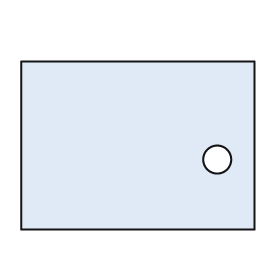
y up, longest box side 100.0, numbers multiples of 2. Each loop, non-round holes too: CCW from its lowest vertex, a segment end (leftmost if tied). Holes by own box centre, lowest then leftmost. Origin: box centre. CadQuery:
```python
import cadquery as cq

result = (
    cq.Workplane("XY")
    .moveTo(-50.0, -36.0)
    .lineTo(50.0, -36.0)
    .lineTo(50.0, 36.0)
    .lineTo(-50.0, 36.0)
    .close()
    .moveTo(34.0, -6.0)
    .circle(6.0)
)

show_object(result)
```